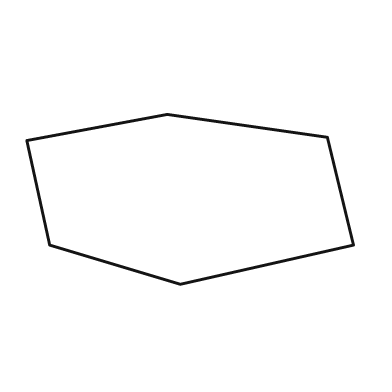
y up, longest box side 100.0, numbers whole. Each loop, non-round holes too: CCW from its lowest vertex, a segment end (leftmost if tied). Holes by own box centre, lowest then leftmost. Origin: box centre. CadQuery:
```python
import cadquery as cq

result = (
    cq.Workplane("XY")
    .moveTo(-3.0, -26.0)
    .lineTo(50.0, -14.0)
    .lineTo(42.0, 19.0)
    .lineTo(-7.0, 26.0)
    .lineTo(-50.0, 18.0)
    .lineTo(-43.0, -14.0)
    .close()
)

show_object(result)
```